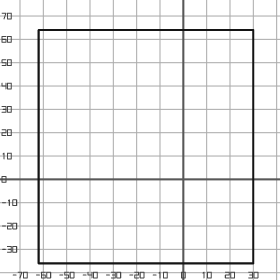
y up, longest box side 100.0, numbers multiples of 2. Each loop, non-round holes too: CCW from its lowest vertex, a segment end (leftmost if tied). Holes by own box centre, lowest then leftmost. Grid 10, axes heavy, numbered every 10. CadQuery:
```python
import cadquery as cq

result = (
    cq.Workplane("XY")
    .moveTo(-62.0, -36.0)
    .lineTo(30.0, -36.0)
    .lineTo(30.0, 64.0)
    .lineTo(-62.0, 64.0)
    .close()
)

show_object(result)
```